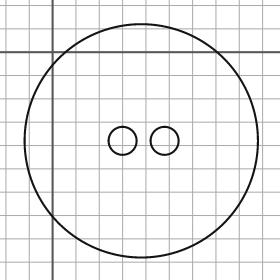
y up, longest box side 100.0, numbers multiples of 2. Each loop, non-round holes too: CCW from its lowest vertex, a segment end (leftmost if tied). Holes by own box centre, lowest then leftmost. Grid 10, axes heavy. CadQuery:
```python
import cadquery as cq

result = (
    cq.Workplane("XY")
    .moveTo(38.0, -38.0)
    .circle(50.0)
    .moveTo(30.0, -38.0)
    .circle(6.0)
    .moveTo(48.0, -38.0)
    .circle(6.0)
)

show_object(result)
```